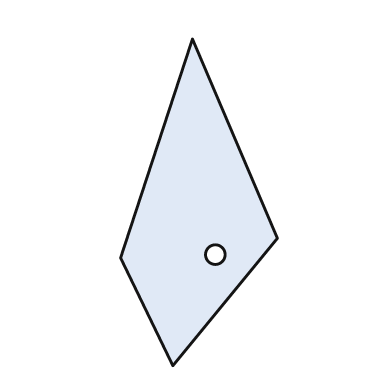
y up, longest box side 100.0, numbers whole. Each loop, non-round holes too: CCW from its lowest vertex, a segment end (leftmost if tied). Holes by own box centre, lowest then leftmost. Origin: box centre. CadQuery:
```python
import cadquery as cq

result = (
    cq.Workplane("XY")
    .moveTo(-8.0, -50.0)
    .lineTo(24.0, -11.0)
    .lineTo(-2.0, 50.0)
    .lineTo(-24.0, -17.0)
    .close()
    .moveTo(5.0, -16.0)
    .circle(3.0)
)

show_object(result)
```